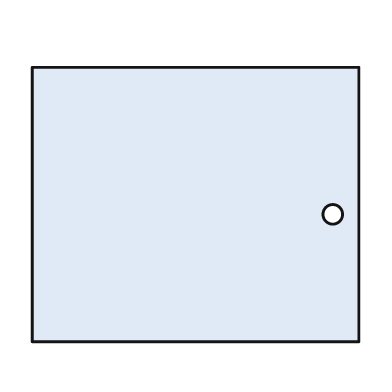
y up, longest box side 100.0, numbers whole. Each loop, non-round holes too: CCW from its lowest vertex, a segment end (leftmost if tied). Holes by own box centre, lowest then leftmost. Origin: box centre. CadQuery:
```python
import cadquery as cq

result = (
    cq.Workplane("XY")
    .moveTo(-50.0, -42.0)
    .lineTo(50.0, -42.0)
    .lineTo(50.0, 42.0)
    .lineTo(-50.0, 42.0)
    .close()
    .moveTo(42.0, -3.0)
    .circle(3.0)
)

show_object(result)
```